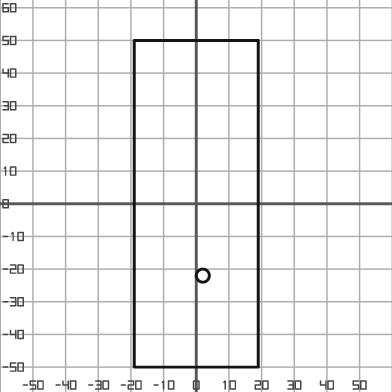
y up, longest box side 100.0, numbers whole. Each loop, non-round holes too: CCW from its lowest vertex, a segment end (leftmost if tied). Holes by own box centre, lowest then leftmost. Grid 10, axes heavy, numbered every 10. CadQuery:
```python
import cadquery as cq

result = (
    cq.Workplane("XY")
    .moveTo(-19.0, -50.0)
    .lineTo(19.0, -50.0)
    .lineTo(19.0, 50.0)
    .lineTo(-19.0, 50.0)
    .close()
    .moveTo(2.0, -22.0)
    .circle(2.0)
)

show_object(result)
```